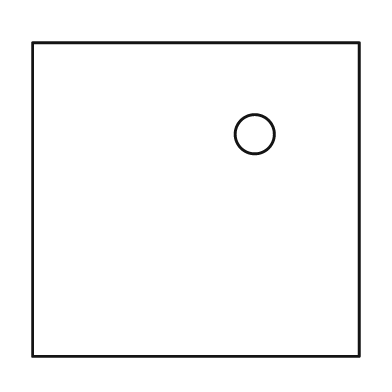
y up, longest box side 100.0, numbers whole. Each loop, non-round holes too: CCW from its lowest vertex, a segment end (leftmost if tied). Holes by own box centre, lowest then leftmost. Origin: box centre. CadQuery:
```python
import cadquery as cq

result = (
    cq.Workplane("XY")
    .moveTo(-50.0, -48.0)
    .lineTo(50.0, -48.0)
    .lineTo(50.0, 48.0)
    .lineTo(-50.0, 48.0)
    .close()
    .moveTo(18.0, 20.0)
    .circle(6.0)
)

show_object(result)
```